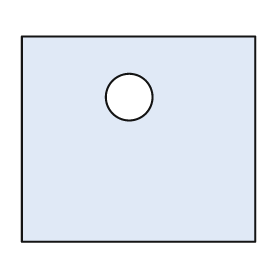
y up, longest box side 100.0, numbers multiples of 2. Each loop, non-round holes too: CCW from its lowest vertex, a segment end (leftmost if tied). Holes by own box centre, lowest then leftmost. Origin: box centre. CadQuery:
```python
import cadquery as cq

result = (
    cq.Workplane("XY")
    .moveTo(-50.0, -44.0)
    .lineTo(50.0, -44.0)
    .lineTo(50.0, 44.0)
    .lineTo(-50.0, 44.0)
    .close()
    .moveTo(-4.0, 18.0)
    .circle(10.0)
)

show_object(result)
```